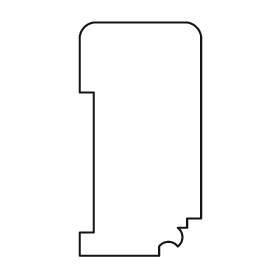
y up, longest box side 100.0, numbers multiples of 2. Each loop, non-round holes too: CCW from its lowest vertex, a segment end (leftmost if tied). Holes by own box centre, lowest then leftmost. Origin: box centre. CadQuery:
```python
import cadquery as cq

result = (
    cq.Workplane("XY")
    .moveTo(-26.0, -50.0)
    .lineTo(8.0, -50.0)
    .lineTo(8.0, -46.0)
    .threePointArc((12.0, -44.0), (16.0, -46.0))
    .threePointArc((18.0, -42.0), (16.0, -38.0))
    .lineTo(20.0, -38.0)
    .lineTo(20.0, -34.0)
    .lineTo(26.0, -34.0)
    .lineTo(26.0, 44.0)
    .threePointArc((24.0, 48.0), (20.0, 50.0))
    .lineTo(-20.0, 50.0)
    .threePointArc((-24.0, 48.0), (-26.0, 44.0))
    .lineTo(-26.0, 20.0)
    .lineTo(-20.0, 20.0)
    .lineTo(-20.0, -40.0)
    .lineTo(-26.0, -40.0)
    .close()
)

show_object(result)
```